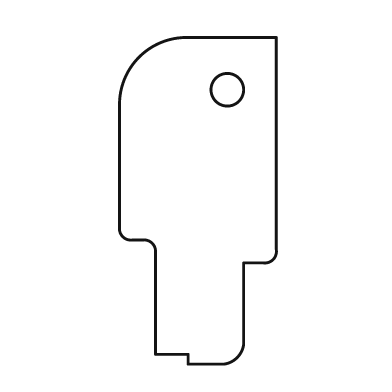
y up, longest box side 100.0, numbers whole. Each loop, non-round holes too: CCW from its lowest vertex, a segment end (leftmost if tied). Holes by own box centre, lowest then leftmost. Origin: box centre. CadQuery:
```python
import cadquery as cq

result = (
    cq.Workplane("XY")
    .moveTo(-3.0, -50.0)
    .lineTo(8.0, -50.0)
    .threePointArc((12.0, -48.0), (14.0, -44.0))
    .lineTo(14.0, -19.0)
    .lineTo(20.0, -19.0)
    .threePointArc((23.0, -18.0), (24.0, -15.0))
    .lineTo(24.0, 50.0)
    .lineTo(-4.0, 50.0)
    .threePointArc((-18.0, 44.0), (-24.0, 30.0))
    .lineTo(-24.0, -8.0)
    .threePointArc((-23.0, -11.0), (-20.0, -12.0))
    .lineTo(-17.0, -12.0)
    .threePointArc((-14.0, -13.0), (-13.0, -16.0))
    .lineTo(-13.0, -47.0)
    .lineTo(-3.0, -47.0)
    .close()
    .moveTo(9.0, 34.0)
    .circle(5.0)
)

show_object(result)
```